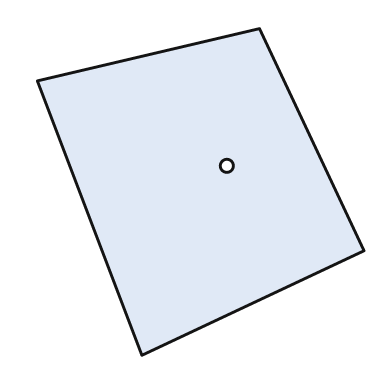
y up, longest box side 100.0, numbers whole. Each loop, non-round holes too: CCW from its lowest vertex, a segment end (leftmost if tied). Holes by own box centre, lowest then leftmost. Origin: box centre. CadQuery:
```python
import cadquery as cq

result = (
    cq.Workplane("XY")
    .moveTo(-18.0, -50.0)
    .lineTo(50.0, -18.0)
    .lineTo(18.0, 50.0)
    .lineTo(-50.0, 34.0)
    .close()
    .moveTo(8.0, 8.0)
    .circle(2.0)
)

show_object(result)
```